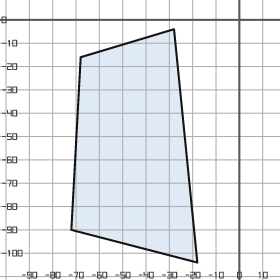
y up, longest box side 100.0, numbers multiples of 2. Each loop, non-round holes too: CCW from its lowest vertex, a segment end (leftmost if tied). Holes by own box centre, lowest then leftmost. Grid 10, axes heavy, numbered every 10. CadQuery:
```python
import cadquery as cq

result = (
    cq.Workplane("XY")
    .moveTo(-18.0, -104.0)
    .lineTo(-28.0, -4.0)
    .lineTo(-68.0, -16.0)
    .lineTo(-72.0, -90.0)
    .close()
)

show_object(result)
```